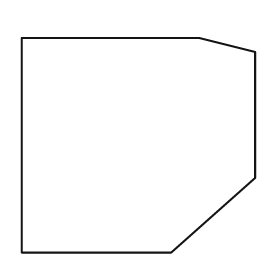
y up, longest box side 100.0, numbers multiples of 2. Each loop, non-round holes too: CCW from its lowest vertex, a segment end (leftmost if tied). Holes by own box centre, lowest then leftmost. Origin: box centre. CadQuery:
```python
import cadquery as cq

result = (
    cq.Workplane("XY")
    .moveTo(-50.0, -46.0)
    .lineTo(14.0, -46.0)
    .lineTo(50.0, -14.0)
    .lineTo(50.0, 40.0)
    .lineTo(26.0, 46.0)
    .lineTo(-50.0, 46.0)
    .close()
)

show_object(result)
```